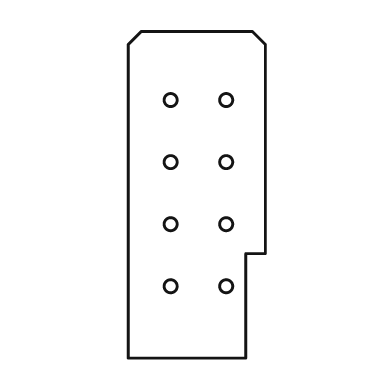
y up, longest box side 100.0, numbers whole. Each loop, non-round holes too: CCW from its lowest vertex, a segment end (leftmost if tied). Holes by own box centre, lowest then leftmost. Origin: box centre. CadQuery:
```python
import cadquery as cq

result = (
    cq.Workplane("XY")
    .moveTo(-21.0, -50.0)
    .lineTo(15.0, -50.0)
    .lineTo(15.0, -18.0)
    .lineTo(21.0, -18.0)
    .lineTo(21.0, 46.0)
    .lineTo(17.0, 50.0)
    .lineTo(-17.0, 50.0)
    .lineTo(-21.0, 46.0)
    .close()
    .moveTo(-8.0, -28.0)
    .circle(2.0)
    .moveTo(9.0, -28.0)
    .circle(2.0)
    .moveTo(-8.0, -9.0)
    .circle(2.0)
    .moveTo(9.0, -9.0)
    .circle(2.0)
    .moveTo(-8.0, 10.0)
    .circle(2.0)
    .moveTo(9.0, 10.0)
    .circle(2.0)
    .moveTo(-8.0, 29.0)
    .circle(2.0)
    .moveTo(9.0, 29.0)
    .circle(2.0)
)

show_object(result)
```